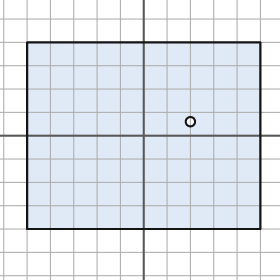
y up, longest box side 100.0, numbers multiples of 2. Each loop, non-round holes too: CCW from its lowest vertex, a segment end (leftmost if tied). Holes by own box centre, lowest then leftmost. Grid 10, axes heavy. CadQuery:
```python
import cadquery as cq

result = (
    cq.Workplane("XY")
    .moveTo(-50.0, -40.0)
    .lineTo(50.0, -40.0)
    .lineTo(50.0, 40.0)
    .lineTo(-50.0, 40.0)
    .close()
    .moveTo(20.0, 6.0)
    .circle(2.0)
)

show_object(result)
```